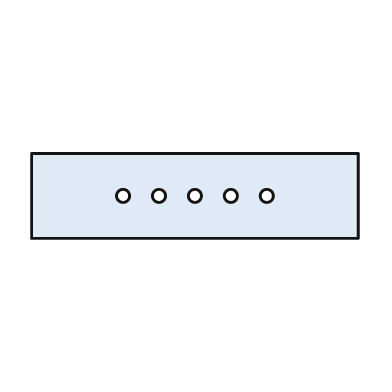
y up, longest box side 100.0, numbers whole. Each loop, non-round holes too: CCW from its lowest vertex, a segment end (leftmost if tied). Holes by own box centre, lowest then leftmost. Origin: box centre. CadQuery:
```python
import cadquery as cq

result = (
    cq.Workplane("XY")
    .moveTo(-50.0, -13.0)
    .lineTo(50.0, -13.0)
    .lineTo(50.0, 13.0)
    .lineTo(-50.0, 13.0)
    .close()
    .moveTo(-22.0, 0.0)
    .circle(2.0)
    .moveTo(-11.0, 0.0)
    .circle(2.0)
    .moveTo(0.0, 0.0)
    .circle(2.0)
    .moveTo(11.0, 0.0)
    .circle(2.0)
    .moveTo(22.0, 0.0)
    .circle(2.0)
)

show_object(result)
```